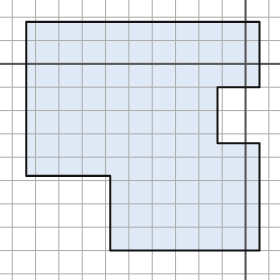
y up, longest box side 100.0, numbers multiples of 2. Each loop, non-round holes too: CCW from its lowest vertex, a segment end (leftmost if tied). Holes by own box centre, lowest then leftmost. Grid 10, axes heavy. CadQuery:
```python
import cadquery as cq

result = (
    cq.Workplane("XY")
    .moveTo(-58.0, -80.0)
    .lineTo(6.0, -80.0)
    .lineTo(6.0, -34.0)
    .lineTo(-12.0, -34.0)
    .lineTo(-12.0, -10.0)
    .lineTo(6.0, -10.0)
    .lineTo(6.0, 18.0)
    .lineTo(-94.0, 18.0)
    .lineTo(-94.0, -48.0)
    .lineTo(-58.0, -48.0)
    .close()
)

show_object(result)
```